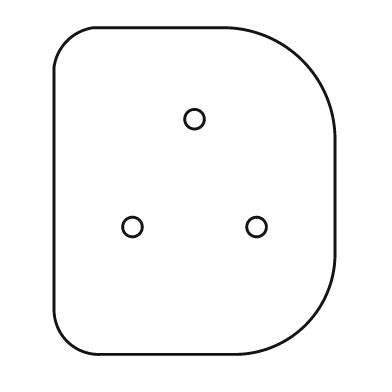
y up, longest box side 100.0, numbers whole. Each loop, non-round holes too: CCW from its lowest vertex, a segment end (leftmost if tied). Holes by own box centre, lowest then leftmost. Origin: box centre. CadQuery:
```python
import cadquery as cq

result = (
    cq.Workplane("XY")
    .moveTo(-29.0, -50.0)
    .lineTo(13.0, -50.0)
    .threePointArc((34.0, -41.0), (43.0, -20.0))
    .lineTo(43.0, 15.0)
    .threePointArc((33.0, 40.0), (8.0, 50.0))
    .lineTo(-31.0, 50.0)
    .threePointArc((-39.0, 46.0), (-43.0, 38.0))
    .lineTo(-43.0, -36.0)
    .threePointArc((-39.0, -46.0), (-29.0, -50.0))
    .close()
    .moveTo(-19.0, -11.0)
    .circle(3.0)
    .moveTo(19.0, -11.0)
    .circle(3.0)
    .moveTo(0.0, 22.0)
    .circle(3.0)
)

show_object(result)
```